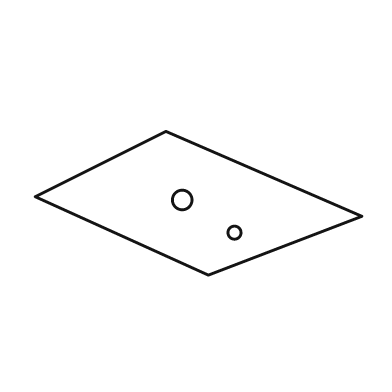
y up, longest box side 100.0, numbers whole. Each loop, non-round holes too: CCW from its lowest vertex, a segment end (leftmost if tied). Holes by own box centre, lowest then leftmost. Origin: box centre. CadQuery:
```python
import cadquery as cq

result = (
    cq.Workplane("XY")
    .moveTo(3.0, -22.0)
    .lineTo(50.0, -4.0)
    .lineTo(-10.0, 22.0)
    .lineTo(-50.0, 2.0)
    .close()
    .moveTo(11.0, -9.0)
    .circle(2.0)
    .moveTo(-5.0, 1.0)
    .circle(3.0)
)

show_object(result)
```